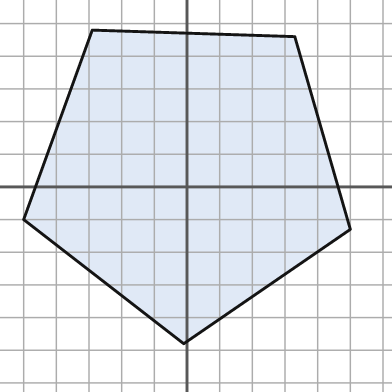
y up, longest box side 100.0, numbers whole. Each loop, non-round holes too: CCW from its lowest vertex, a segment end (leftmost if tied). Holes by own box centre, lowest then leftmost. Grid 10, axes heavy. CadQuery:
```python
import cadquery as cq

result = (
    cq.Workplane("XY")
    .moveTo(-1.0, -48.0)
    .lineTo(50.0, -13.0)
    .lineTo(33.0, 46.0)
    .lineTo(-29.0, 48.0)
    .lineTo(-50.0, -10.0)
    .close()
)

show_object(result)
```